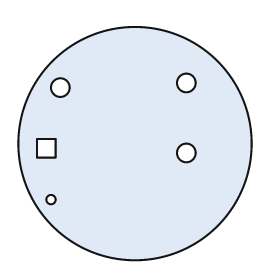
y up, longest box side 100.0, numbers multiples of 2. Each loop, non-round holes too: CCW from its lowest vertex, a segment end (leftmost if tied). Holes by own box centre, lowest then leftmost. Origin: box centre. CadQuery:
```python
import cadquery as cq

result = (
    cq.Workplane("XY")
    .moveTo(0.0, 0.0)
    .circle(50.0)
    .moveTo(-36.0, -24.0)
    .circle(2.0)
    .moveTo(22.0, -4.0)
    .circle(4.0)
    .moveTo(-42.0, -6.0)
    .lineTo(-34.0, -6.0)
    .lineTo(-34.0, 2.0)
    .lineTo(-42.0, 2.0)
    .close()
    .moveTo(-32.0, 24.0)
    .circle(4.0)
    .moveTo(22.0, 26.0)
    .circle(4.0)
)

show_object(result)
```